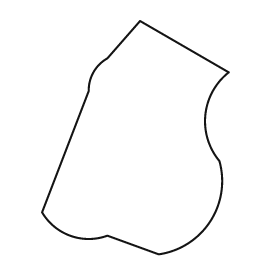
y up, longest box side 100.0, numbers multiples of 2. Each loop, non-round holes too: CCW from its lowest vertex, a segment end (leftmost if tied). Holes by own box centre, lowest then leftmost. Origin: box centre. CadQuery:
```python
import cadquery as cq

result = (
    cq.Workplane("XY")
    .moveTo(10.0, -50.0)
    .threePointArc((32.0, -36.0), (36.0, -10.0))
    .threePointArc((30.0, 10.0), (40.0, 28.0))
    .lineTo(2.0, 50.0)
    .lineTo(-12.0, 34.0)
    .threePointArc((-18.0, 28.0), (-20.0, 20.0))
    .lineTo(-40.0, -32.0)
    .threePointArc((-28.0, -42.0), (-12.0, -42.0))
    .close()
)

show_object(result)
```